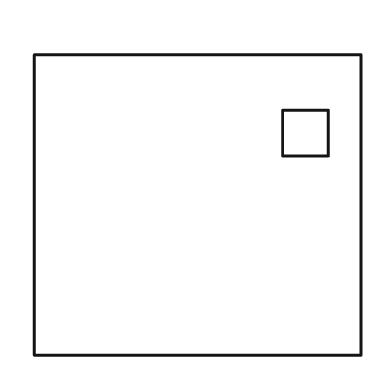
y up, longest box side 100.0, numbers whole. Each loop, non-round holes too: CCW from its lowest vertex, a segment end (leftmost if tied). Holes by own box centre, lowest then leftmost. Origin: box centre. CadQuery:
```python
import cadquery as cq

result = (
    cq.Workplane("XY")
    .moveTo(-50.0, -46.0)
    .lineTo(50.0, -46.0)
    .lineTo(50.0, 46.0)
    .lineTo(-50.0, 46.0)
    .close()
    .moveTo(26.0, 15.0)
    .lineTo(40.0, 15.0)
    .lineTo(40.0, 29.0)
    .lineTo(26.0, 29.0)
    .close()
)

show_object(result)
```